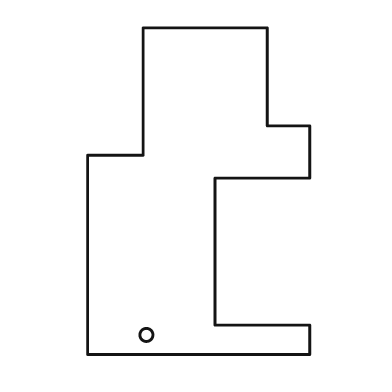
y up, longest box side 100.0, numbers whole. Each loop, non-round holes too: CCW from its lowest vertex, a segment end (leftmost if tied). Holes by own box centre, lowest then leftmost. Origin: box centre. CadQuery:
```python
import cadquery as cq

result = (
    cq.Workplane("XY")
    .moveTo(-34.0, -50.0)
    .lineTo(34.0, -50.0)
    .lineTo(34.0, -41.0)
    .lineTo(5.0, -41.0)
    .lineTo(5.0, 4.0)
    .lineTo(34.0, 4.0)
    .lineTo(34.0, 20.0)
    .lineTo(21.0, 20.0)
    .lineTo(21.0, 50.0)
    .lineTo(-17.0, 50.0)
    .lineTo(-17.0, 11.0)
    .lineTo(-34.0, 11.0)
    .close()
    .moveTo(-16.0, -44.0)
    .circle(2.0)
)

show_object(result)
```